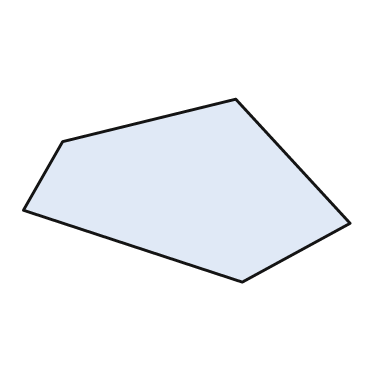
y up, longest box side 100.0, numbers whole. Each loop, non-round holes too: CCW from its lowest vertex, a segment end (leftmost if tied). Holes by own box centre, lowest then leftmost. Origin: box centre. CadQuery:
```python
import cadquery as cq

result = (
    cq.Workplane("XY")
    .moveTo(17.0, -28.0)
    .lineTo(50.0, -10.0)
    .lineTo(15.0, 28.0)
    .lineTo(-38.0, 15.0)
    .lineTo(-50.0, -6.0)
    .close()
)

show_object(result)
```